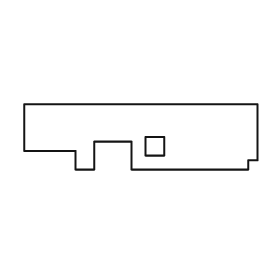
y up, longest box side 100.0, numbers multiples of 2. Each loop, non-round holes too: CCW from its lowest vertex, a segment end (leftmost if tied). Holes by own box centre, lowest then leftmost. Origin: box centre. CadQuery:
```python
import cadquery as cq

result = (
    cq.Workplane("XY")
    .moveTo(-28.0, -14.0)
    .lineTo(-20.0, -14.0)
    .lineTo(-20.0, -2.0)
    .lineTo(-4.0, -2.0)
    .lineTo(-4.0, -14.0)
    .lineTo(46.0, -14.0)
    .lineTo(46.0, -10.0)
    .lineTo(50.0, -10.0)
    .lineTo(50.0, 14.0)
    .lineTo(-50.0, 14.0)
    .lineTo(-50.0, -6.0)
    .lineTo(-28.0, -6.0)
    .close()
    .moveTo(2.0, -8.0)
    .lineTo(10.0, -8.0)
    .lineTo(10.0, 0.0)
    .lineTo(2.0, 0.0)
    .close()
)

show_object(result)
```